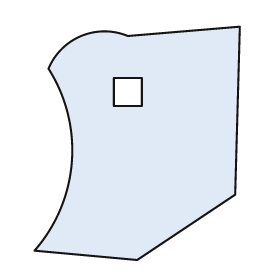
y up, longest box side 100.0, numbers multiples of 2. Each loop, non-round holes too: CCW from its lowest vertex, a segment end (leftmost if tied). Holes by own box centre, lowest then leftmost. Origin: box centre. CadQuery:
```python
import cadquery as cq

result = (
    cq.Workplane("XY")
    .moveTo(0.0, -50.0)
    .lineTo(42.0, -22.0)
    .lineTo(44.0, 50.0)
    .lineTo(-4.0, 46.0)
    .threePointArc((-24.0, 46.0), (-38.0, 32.0))
    .threePointArc((-28.0, -8.0), (-44.0, -46.0))
    .close()
    .moveTo(-10.0, 16.0)
    .lineTo(2.0, 16.0)
    .lineTo(2.0, 28.0)
    .lineTo(-10.0, 28.0)
    .close()
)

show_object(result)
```